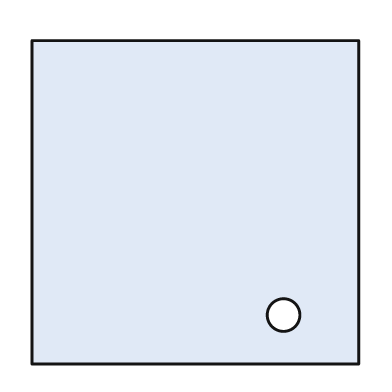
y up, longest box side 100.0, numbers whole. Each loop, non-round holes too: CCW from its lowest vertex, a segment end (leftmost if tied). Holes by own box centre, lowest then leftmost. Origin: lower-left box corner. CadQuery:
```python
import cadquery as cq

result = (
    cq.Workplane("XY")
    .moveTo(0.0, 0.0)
    .lineTo(100.0, 0.0)
    .lineTo(100.0, 99.0)
    .lineTo(0.0, 99.0)
    .close()
    .moveTo(77.0, 15.0)
    .circle(5.0)
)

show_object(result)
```